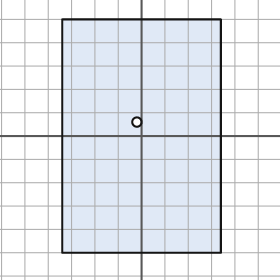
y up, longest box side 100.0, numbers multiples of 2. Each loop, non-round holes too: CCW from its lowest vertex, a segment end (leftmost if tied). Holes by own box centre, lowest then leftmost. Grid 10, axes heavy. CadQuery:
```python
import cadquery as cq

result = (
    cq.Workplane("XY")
    .moveTo(-34.0, -50.0)
    .lineTo(34.0, -50.0)
    .lineTo(34.0, 50.0)
    .lineTo(-34.0, 50.0)
    .close()
    .moveTo(-2.0, 6.0)
    .circle(2.0)
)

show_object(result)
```